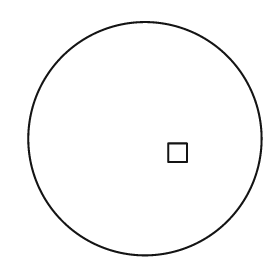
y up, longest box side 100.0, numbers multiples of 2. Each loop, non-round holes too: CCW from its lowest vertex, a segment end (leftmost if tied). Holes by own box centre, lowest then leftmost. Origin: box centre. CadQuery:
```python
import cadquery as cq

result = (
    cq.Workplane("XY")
    .moveTo(0.0, 0.0)
    .circle(50.0)
    .moveTo(10.0, -10.0)
    .lineTo(18.0, -10.0)
    .lineTo(18.0, -2.0)
    .lineTo(10.0, -2.0)
    .close()
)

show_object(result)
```